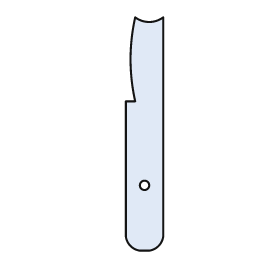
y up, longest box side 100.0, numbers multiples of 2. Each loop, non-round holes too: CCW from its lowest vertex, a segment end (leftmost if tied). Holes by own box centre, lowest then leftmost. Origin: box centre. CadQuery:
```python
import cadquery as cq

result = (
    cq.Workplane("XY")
    .moveTo(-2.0, -50.0)
    .lineTo(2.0, -50.0)
    .threePointArc((6.0, -48.0), (8.0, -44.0))
    .lineTo(8.0, 50.0)
    .threePointArc((2.0, 48.0), (-4.0, 50.0))
    .threePointArc((-6.0, 32.0), (-4.0, 14.0))
    .lineTo(-8.0, 14.0)
    .lineTo(-8.0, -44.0)
    .threePointArc((-6.0, -48.0), (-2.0, -50.0))
    .close()
    .moveTo(0.0, -22.0)
    .circle(2.0)
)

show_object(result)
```